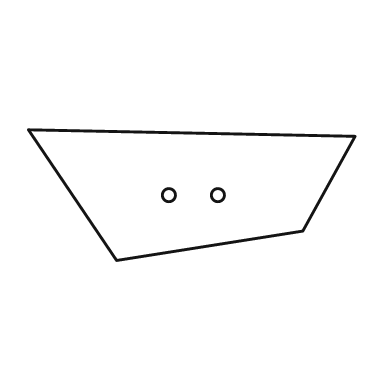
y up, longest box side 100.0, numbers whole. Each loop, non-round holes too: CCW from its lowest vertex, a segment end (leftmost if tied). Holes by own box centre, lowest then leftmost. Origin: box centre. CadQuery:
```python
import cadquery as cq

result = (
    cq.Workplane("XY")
    .moveTo(-23.0, -20.0)
    .lineTo(34.0, -11.0)
    .lineTo(50.0, 18.0)
    .lineTo(-50.0, 20.0)
    .close()
    .moveTo(-7.0, 0.0)
    .circle(2.0)
    .moveTo(8.0, 0.0)
    .circle(2.0)
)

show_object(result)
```